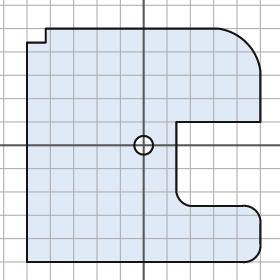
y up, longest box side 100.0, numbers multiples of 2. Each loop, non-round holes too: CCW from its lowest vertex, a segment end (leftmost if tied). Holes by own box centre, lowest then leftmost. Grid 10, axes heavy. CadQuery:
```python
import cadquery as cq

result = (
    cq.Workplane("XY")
    .moveTo(-50.0, -50.0)
    .lineTo(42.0, -50.0)
    .threePointArc((48.0, -48.0), (50.0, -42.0))
    .lineTo(50.0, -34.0)
    .threePointArc((48.0, -28.0), (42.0, -26.0))
    .lineTo(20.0, -26.0)
    .threePointArc((16.0, -24.0), (14.0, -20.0))
    .lineTo(14.0, 10.0)
    .lineTo(50.0, 10.0)
    .lineTo(50.0, 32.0)
    .threePointArc((44.0, 44.0), (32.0, 50.0))
    .lineTo(-42.0, 50.0)
    .lineTo(-42.0, 44.0)
    .lineTo(-50.0, 44.0)
    .close()
    .moveTo(0.0, 0.0)
    .circle(4.0)
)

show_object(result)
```